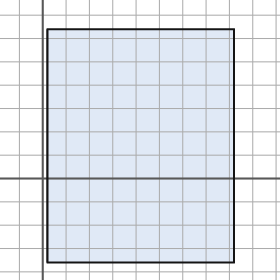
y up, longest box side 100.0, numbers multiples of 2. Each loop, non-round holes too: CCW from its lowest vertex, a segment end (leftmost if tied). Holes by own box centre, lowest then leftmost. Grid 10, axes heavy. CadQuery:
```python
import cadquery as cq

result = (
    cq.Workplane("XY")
    .moveTo(2.0, -36.0)
    .lineTo(82.0, -36.0)
    .lineTo(82.0, 64.0)
    .lineTo(2.0, 64.0)
    .close()
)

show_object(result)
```